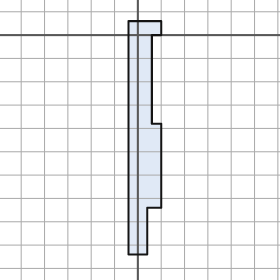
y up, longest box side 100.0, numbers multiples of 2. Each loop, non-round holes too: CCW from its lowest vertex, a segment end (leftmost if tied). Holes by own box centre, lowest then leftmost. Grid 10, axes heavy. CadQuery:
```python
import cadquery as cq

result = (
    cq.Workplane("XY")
    .moveTo(-4.0, -94.0)
    .lineTo(4.0, -94.0)
    .lineTo(4.0, -74.0)
    .lineTo(10.0, -74.0)
    .lineTo(10.0, -38.0)
    .lineTo(6.0, -38.0)
    .lineTo(6.0, 0.0)
    .lineTo(10.0, 0.0)
    .lineTo(10.0, 6.0)
    .lineTo(-4.0, 6.0)
    .close()
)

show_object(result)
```